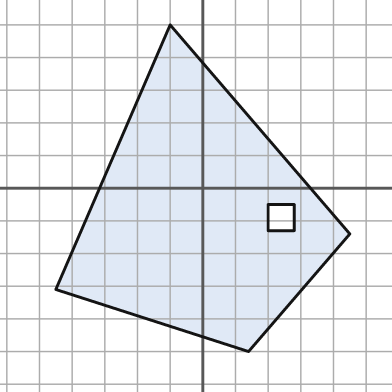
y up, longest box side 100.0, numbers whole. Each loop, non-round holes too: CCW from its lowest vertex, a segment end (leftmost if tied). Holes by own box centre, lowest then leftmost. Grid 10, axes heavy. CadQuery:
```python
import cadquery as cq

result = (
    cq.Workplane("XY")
    .moveTo(14.0, -50.0)
    .lineTo(45.0, -14.0)
    .lineTo(-10.0, 50.0)
    .lineTo(-45.0, -31.0)
    .close()
    .moveTo(20.0, -13.0)
    .lineTo(28.0, -13.0)
    .lineTo(28.0, -5.0)
    .lineTo(20.0, -5.0)
    .close()
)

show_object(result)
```